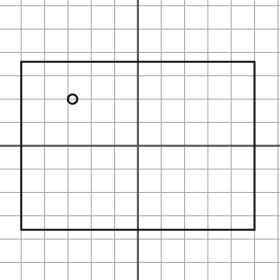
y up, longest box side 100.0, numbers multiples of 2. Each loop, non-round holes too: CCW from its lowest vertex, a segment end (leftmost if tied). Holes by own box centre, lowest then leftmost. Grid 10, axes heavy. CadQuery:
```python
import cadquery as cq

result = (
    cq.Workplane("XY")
    .moveTo(-50.0, -36.0)
    .lineTo(50.0, -36.0)
    .lineTo(50.0, 36.0)
    .lineTo(-50.0, 36.0)
    .close()
    .moveTo(-28.0, 20.0)
    .circle(2.0)
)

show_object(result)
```